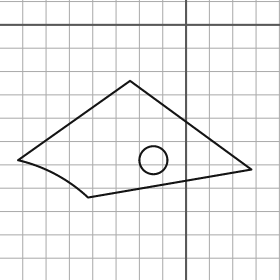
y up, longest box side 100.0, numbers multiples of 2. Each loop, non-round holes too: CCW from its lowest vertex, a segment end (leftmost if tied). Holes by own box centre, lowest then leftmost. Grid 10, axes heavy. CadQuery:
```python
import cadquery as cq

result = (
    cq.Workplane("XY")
    .moveTo(-42.0, -74.0)
    .lineTo(28.0, -62.0)
    .lineTo(-24.0, -24.0)
    .lineTo(-72.0, -58.0)
    .threePointArc((-56.0, -64.0), (-42.0, -74.0))
    .close()
    .moveTo(-14.0, -58.0)
    .circle(6.0)
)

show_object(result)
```